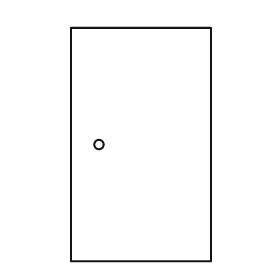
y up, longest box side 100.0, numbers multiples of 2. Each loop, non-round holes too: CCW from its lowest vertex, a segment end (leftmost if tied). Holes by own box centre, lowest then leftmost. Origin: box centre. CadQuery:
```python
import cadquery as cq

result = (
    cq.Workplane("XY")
    .moveTo(-30.0, -50.0)
    .lineTo(30.0, -50.0)
    .lineTo(30.0, 50.0)
    .lineTo(-30.0, 50.0)
    .close()
    .moveTo(-18.0, 0.0)
    .circle(2.0)
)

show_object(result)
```